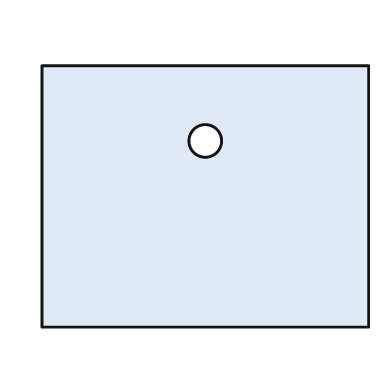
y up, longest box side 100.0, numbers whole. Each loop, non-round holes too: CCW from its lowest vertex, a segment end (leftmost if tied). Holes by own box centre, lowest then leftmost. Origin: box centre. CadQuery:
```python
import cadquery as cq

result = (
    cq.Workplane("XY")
    .moveTo(-50.0, -40.0)
    .lineTo(50.0, -40.0)
    .lineTo(50.0, 40.0)
    .lineTo(-50.0, 40.0)
    .close()
    .moveTo(0.0, 17.0)
    .circle(5.0)
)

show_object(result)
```